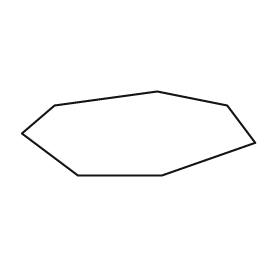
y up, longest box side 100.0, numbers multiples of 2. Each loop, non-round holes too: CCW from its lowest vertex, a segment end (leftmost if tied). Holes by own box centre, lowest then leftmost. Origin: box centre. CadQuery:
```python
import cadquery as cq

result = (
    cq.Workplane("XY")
    .moveTo(-26.0, -18.0)
    .lineTo(10.0, -18.0)
    .lineTo(50.0, -4.0)
    .lineTo(38.0, 12.0)
    .lineTo(8.0, 18.0)
    .lineTo(-36.0, 12.0)
    .lineTo(-50.0, 0.0)
    .close()
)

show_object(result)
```